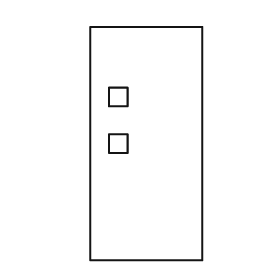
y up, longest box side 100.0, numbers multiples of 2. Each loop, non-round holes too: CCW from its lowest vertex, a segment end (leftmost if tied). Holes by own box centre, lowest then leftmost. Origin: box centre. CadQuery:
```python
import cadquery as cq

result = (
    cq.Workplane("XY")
    .moveTo(-24.0, -50.0)
    .lineTo(24.0, -50.0)
    .lineTo(24.0, 50.0)
    .lineTo(-24.0, 50.0)
    .close()
    .moveTo(-16.0, -4.0)
    .lineTo(-8.0, -4.0)
    .lineTo(-8.0, 4.0)
    .lineTo(-16.0, 4.0)
    .close()
    .moveTo(-16.0, 16.0)
    .lineTo(-8.0, 16.0)
    .lineTo(-8.0, 24.0)
    .lineTo(-16.0, 24.0)
    .close()
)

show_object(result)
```